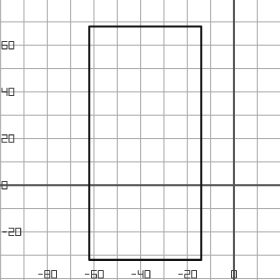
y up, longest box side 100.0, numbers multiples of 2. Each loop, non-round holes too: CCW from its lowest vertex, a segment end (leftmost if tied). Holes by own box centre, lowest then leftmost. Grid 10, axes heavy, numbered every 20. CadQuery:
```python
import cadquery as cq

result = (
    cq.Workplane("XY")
    .moveTo(-62.0, -32.0)
    .lineTo(-14.0, -32.0)
    .lineTo(-14.0, 68.0)
    .lineTo(-62.0, 68.0)
    .close()
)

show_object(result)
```